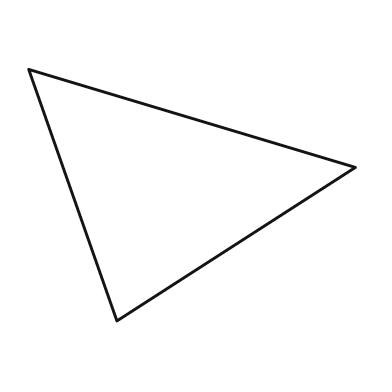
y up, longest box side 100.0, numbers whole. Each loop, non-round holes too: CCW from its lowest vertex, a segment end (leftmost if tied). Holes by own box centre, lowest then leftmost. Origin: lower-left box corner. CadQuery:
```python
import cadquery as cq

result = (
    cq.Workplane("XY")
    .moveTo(27.0, 0.0)
    .lineTo(100.0, 47.0)
    .lineTo(0.0, 77.0)
    .close()
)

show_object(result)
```